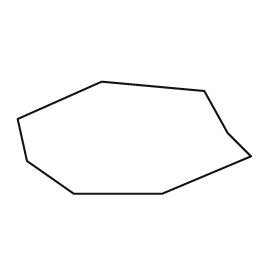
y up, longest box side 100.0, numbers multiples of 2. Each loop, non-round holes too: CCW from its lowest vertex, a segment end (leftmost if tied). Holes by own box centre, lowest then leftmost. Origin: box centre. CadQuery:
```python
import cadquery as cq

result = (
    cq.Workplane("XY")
    .moveTo(-26.0, -24.0)
    .lineTo(12.0, -24.0)
    .lineTo(50.0, -8.0)
    .lineTo(40.0, 2.0)
    .lineTo(30.0, 20.0)
    .lineTo(-14.0, 24.0)
    .lineTo(-50.0, 8.0)
    .lineTo(-46.0, -10.0)
    .close()
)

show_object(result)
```